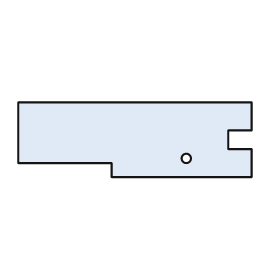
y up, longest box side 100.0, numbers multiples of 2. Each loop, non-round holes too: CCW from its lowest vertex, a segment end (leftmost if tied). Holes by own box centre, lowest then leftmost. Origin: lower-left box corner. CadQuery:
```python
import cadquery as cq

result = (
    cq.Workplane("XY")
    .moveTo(40.0, 0.0)
    .lineTo(100.0, 0.0)
    .lineTo(100.0, 12.0)
    .lineTo(90.0, 12.0)
    .lineTo(90.0, 20.0)
    .lineTo(100.0, 20.0)
    .lineTo(100.0, 32.0)
    .lineTo(0.0, 32.0)
    .lineTo(0.0, 6.0)
    .lineTo(40.0, 6.0)
    .close()
    .moveTo(72.0, 8.0)
    .circle(2.0)
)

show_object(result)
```